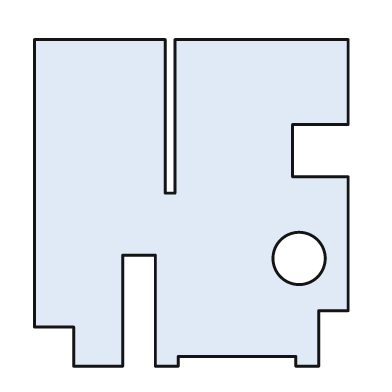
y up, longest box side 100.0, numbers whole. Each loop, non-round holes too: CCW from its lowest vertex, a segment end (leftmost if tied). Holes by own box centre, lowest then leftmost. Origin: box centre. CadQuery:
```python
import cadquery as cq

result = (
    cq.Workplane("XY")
    .moveTo(-36.0, -50.0)
    .lineTo(-21.0, -50.0)
    .lineTo(-21.0, -16.0)
    .lineTo(-11.0, -16.0)
    .lineTo(-11.0, -50.0)
    .lineTo(-4.0, -50.0)
    .lineTo(-4.0, -47.0)
    .lineTo(32.0, -47.0)
    .lineTo(32.0, -50.0)
    .lineTo(39.0, -50.0)
    .lineTo(39.0, -33.0)
    .lineTo(48.0, -33.0)
    .lineTo(48.0, 8.0)
    .lineTo(31.0, 8.0)
    .lineTo(31.0, 24.0)
    .lineTo(48.0, 24.0)
    .lineTo(48.0, 50.0)
    .lineTo(-5.0, 50.0)
    .lineTo(-5.0, 3.0)
    .lineTo(-8.0, 3.0)
    .lineTo(-8.0, 50.0)
    .lineTo(-48.0, 50.0)
    .lineTo(-48.0, -38.0)
    .lineTo(-36.0, -38.0)
    .close()
    .moveTo(33.0, -17.0)
    .circle(8.0)
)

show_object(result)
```